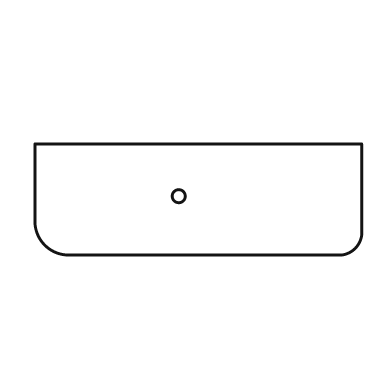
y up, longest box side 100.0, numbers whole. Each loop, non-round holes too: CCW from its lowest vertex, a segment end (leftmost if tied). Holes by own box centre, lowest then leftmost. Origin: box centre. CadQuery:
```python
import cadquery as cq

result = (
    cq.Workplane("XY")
    .moveTo(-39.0, -17.0)
    .lineTo(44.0, -17.0)
    .threePointArc((48.0, -15.0), (50.0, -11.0))
    .lineTo(50.0, 17.0)
    .lineTo(-50.0, 17.0)
    .lineTo(-50.0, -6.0)
    .threePointArc((-47.0, -14.0), (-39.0, -17.0))
    .close()
    .moveTo(-6.0, 1.0)
    .circle(2.0)
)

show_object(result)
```